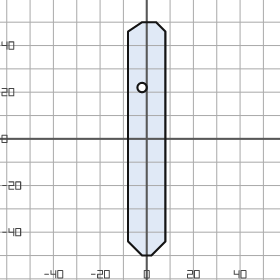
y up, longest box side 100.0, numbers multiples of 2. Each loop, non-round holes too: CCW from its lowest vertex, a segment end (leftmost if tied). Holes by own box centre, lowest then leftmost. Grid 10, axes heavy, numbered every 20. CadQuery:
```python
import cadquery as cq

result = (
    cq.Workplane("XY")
    .moveTo(-2.0, -50.0)
    .lineTo(2.0, -50.0)
    .lineTo(8.0, -44.0)
    .lineTo(8.0, 46.0)
    .lineTo(4.0, 50.0)
    .lineTo(-2.0, 50.0)
    .lineTo(-8.0, 46.0)
    .lineTo(-8.0, -44.0)
    .close()
    .moveTo(-2.0, 22.0)
    .circle(2.0)
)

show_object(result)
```